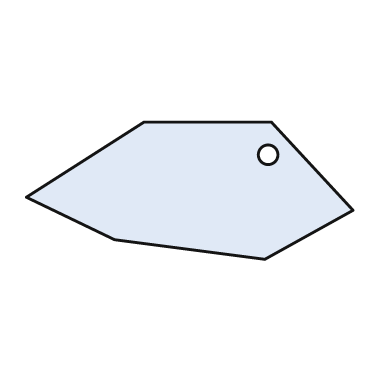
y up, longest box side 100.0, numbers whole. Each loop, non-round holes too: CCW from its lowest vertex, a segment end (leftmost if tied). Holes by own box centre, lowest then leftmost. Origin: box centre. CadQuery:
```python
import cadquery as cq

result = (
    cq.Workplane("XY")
    .moveTo(23.0, -21.0)
    .lineTo(50.0, -6.0)
    .lineTo(25.0, 21.0)
    .lineTo(-14.0, 21.0)
    .lineTo(-50.0, -2.0)
    .lineTo(-23.0, -15.0)
    .close()
    .moveTo(24.0, 11.0)
    .circle(3.0)
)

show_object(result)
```